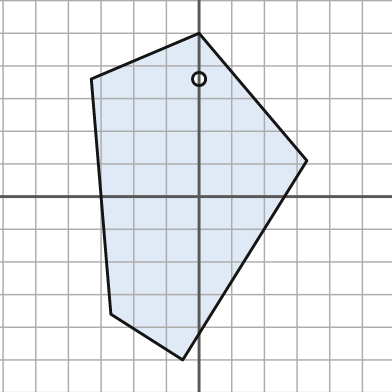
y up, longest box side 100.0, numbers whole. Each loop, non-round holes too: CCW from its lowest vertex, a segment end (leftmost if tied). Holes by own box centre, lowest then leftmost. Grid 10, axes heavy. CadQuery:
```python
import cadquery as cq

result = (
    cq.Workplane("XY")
    .moveTo(-5.0, -50.0)
    .lineTo(33.0, 11.0)
    .lineTo(0.0, 50.0)
    .lineTo(-33.0, 36.0)
    .lineTo(-27.0, -36.0)
    .close()
    .moveTo(0.0, 36.0)
    .circle(2.0)
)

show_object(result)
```